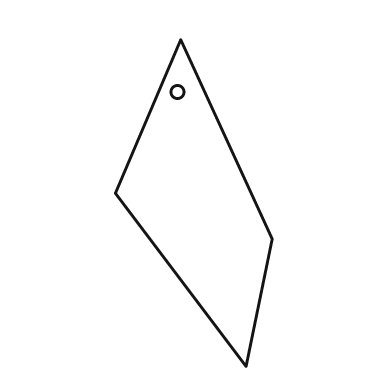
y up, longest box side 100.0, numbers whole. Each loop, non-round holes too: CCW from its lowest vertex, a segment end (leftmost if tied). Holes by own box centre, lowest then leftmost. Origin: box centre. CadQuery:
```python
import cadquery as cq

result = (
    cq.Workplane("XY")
    .moveTo(16.0, -50.0)
    .lineTo(24.0, -11.0)
    .lineTo(-4.0, 50.0)
    .lineTo(-24.0, 3.0)
    .close()
    .moveTo(-5.0, 34.0)
    .circle(2.0)
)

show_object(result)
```